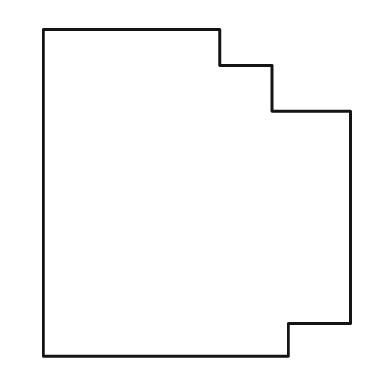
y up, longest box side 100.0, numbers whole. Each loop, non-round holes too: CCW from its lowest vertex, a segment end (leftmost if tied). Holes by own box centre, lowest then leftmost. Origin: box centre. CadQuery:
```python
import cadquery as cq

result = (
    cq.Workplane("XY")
    .moveTo(-47.0, -50.0)
    .lineTo(28.0, -50.0)
    .lineTo(28.0, -40.0)
    .lineTo(47.0, -40.0)
    .lineTo(47.0, 25.0)
    .lineTo(23.0, 25.0)
    .lineTo(23.0, 39.0)
    .lineTo(7.0, 39.0)
    .lineTo(7.0, 50.0)
    .lineTo(-47.0, 50.0)
    .close()
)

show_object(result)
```